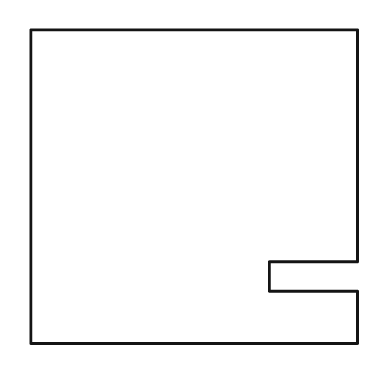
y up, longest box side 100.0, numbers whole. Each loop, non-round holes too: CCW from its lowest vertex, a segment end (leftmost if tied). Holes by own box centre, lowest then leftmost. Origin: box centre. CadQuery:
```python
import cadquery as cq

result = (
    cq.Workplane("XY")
    .moveTo(-50.0, -48.0)
    .lineTo(50.0, -48.0)
    .lineTo(50.0, -32.0)
    .lineTo(23.0, -32.0)
    .lineTo(23.0, -23.0)
    .lineTo(50.0, -23.0)
    .lineTo(50.0, 48.0)
    .lineTo(-50.0, 48.0)
    .close()
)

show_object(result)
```